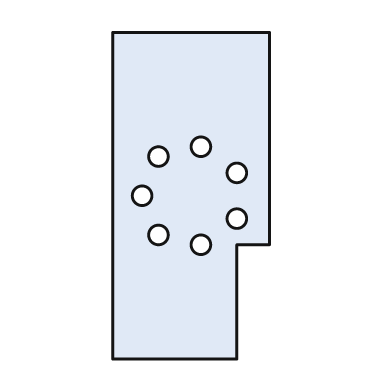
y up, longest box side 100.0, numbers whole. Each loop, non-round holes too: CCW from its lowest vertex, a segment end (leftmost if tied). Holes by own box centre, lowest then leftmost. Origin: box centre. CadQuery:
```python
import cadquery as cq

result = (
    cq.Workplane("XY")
    .moveTo(-24.0, -50.0)
    .lineTo(14.0, -50.0)
    .lineTo(14.0, -15.0)
    .lineTo(24.0, -15.0)
    .lineTo(24.0, 50.0)
    .lineTo(-24.0, 50.0)
    .close()
    .moveTo(3.0, -15.0)
    .circle(3.0)
    .moveTo(-10.0, -12.0)
    .circle(3.0)
    .moveTo(14.0, -7.0)
    .circle(3.0)
    .moveTo(-15.0, 0.0)
    .circle(3.0)
    .moveTo(14.0, 7.0)
    .circle(3.0)
    .moveTo(-10.0, 12.0)
    .circle(3.0)
    .moveTo(3.0, 15.0)
    .circle(3.0)
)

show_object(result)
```